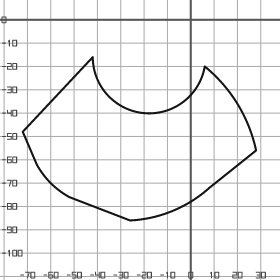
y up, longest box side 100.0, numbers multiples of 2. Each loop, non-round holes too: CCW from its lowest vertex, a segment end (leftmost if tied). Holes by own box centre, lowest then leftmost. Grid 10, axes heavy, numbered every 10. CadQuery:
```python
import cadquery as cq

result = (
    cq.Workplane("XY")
    .moveTo(-26.0, -86.0)
    .threePointArc((-8.0, -82.0), (8.0, -72.0))
    .lineTo(28.0, -56.0)
    .threePointArc((20.0, -36.0), (6.0, -20.0))
    .threePointArc((-20.0, -40.0), (-42.0, -16.0))
    .lineTo(-72.0, -48.0)
    .lineTo(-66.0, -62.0)
    .threePointArc((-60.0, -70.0), (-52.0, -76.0))
    .close()
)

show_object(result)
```